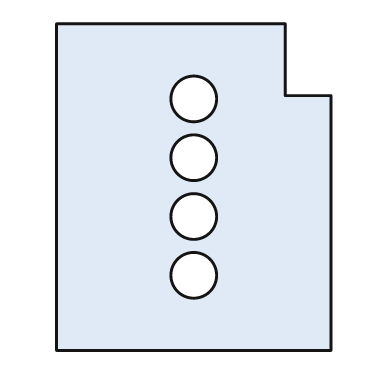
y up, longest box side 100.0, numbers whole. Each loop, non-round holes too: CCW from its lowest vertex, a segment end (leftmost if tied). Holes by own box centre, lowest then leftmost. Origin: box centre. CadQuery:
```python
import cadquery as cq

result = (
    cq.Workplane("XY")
    .moveTo(-42.0, -50.0)
    .lineTo(42.0, -50.0)
    .lineTo(42.0, 28.0)
    .lineTo(28.0, 28.0)
    .lineTo(28.0, 50.0)
    .lineTo(-42.0, 50.0)
    .close()
    .moveTo(0.0, -27.0)
    .circle(7.0)
    .moveTo(0.0, -9.0)
    .circle(7.0)
    .moveTo(0.0, 9.0)
    .circle(7.0)
    .moveTo(0.0, 27.0)
    .circle(7.0)
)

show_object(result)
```